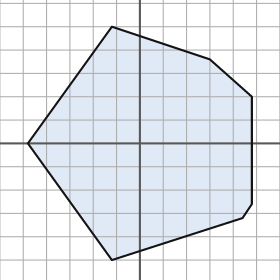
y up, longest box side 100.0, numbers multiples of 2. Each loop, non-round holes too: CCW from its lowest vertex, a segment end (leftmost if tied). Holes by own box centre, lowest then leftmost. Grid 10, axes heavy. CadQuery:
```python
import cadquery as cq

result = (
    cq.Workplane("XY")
    .moveTo(-12.0, -50.0)
    .lineTo(44.0, -32.0)
    .lineTo(48.0, -26.0)
    .lineTo(48.0, 20.0)
    .lineTo(30.0, 36.0)
    .lineTo(-12.0, 50.0)
    .lineTo(-48.0, 0.0)
    .close()
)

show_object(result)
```